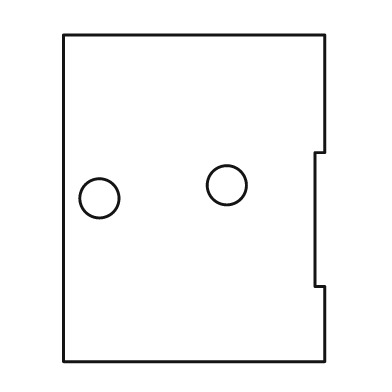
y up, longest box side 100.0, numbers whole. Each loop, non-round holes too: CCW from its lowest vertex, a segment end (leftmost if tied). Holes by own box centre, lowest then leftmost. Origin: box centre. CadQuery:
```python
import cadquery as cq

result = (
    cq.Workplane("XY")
    .moveTo(-40.0, -50.0)
    .lineTo(40.0, -50.0)
    .lineTo(40.0, -27.0)
    .lineTo(37.0, -27.0)
    .lineTo(37.0, 14.0)
    .lineTo(40.0, 14.0)
    .lineTo(40.0, 50.0)
    .lineTo(-40.0, 50.0)
    .close()
    .moveTo(-29.0, 0.0)
    .circle(6.0)
    .moveTo(10.0, 4.0)
    .circle(6.0)
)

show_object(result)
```